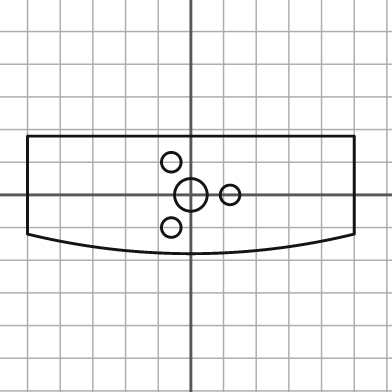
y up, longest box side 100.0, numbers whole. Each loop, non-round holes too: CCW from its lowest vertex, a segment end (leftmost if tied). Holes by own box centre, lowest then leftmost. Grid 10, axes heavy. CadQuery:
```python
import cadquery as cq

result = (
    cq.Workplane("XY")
    .moveTo(-50.0, -12.0)
    .threePointArc((0.0, -18.0), (50.0, -12.0))
    .lineTo(50.0, 18.0)
    .lineTo(-50.0, 18.0)
    .close()
    .moveTo(-6.0, -10.0)
    .circle(3.0)
    .moveTo(0.0, 0.0)
    .circle(5.0)
    .moveTo(12.0, 0.0)
    .circle(3.0)
    .moveTo(-6.0, 10.0)
    .circle(3.0)
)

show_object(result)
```